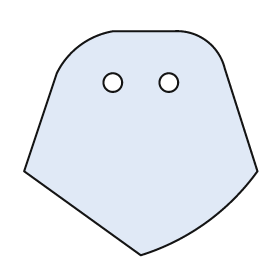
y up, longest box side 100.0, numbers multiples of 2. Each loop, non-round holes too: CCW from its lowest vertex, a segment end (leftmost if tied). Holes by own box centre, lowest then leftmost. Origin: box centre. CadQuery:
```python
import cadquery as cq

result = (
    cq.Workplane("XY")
    .moveTo(0.0, -48.0)
    .threePointArc((28.0, -34.0), (50.0, -12.0))
    .lineTo(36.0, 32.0)
    .threePointArc((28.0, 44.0), (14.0, 48.0))
    .lineTo(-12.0, 48.0)
    .threePointArc((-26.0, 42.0), (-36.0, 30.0))
    .lineTo(-50.0, -12.0)
    .close()
    .moveTo(-12.0, 26.0)
    .circle(4.0)
    .moveTo(12.0, 26.0)
    .circle(4.0)
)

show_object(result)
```